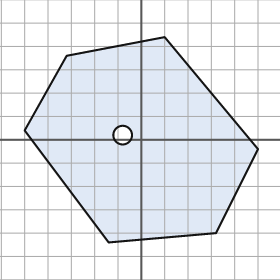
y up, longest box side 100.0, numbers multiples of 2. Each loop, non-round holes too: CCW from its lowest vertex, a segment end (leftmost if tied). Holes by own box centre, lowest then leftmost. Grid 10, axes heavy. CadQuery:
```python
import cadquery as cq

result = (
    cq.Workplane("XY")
    .moveTo(-14.0, -44.0)
    .lineTo(32.0, -40.0)
    .lineTo(50.0, -4.0)
    .lineTo(10.0, 44.0)
    .lineTo(-32.0, 36.0)
    .lineTo(-50.0, 4.0)
    .close()
    .moveTo(-8.0, 2.0)
    .circle(4.0)
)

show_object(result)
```